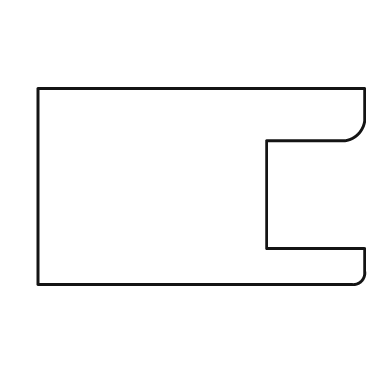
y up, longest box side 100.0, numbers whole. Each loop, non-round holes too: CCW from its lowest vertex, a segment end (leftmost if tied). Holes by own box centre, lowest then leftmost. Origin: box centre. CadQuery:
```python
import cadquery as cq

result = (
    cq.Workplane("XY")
    .moveTo(-50.0, -30.0)
    .lineTo(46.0, -30.0)
    .threePointArc((49.0, -29.0), (50.0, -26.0))
    .lineTo(50.0, -19.0)
    .lineTo(20.0, -19.0)
    .lineTo(20.0, 14.0)
    .lineTo(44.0, 14.0)
    .threePointArc((48.0, 16.0), (50.0, 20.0))
    .lineTo(50.0, 30.0)
    .lineTo(-50.0, 30.0)
    .close()
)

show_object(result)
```